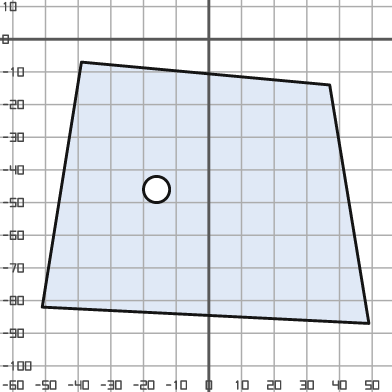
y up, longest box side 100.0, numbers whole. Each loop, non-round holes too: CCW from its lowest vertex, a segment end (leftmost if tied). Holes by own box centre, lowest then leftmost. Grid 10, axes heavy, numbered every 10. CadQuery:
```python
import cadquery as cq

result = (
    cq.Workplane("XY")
    .moveTo(49.0, -87.0)
    .lineTo(37.0, -14.0)
    .lineTo(-39.0, -7.0)
    .lineTo(-51.0, -82.0)
    .close()
    .moveTo(-16.0, -46.0)
    .circle(4.0)
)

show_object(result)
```